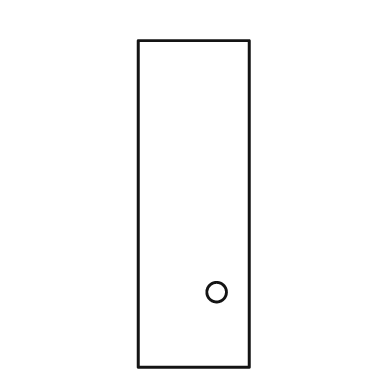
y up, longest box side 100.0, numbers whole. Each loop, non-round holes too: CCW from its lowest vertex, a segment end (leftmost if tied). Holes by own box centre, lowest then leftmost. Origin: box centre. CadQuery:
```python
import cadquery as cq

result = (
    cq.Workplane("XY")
    .moveTo(-17.0, -50.0)
    .lineTo(17.0, -50.0)
    .lineTo(17.0, 50.0)
    .lineTo(-17.0, 50.0)
    .close()
    .moveTo(7.0, -27.0)
    .circle(3.0)
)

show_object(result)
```